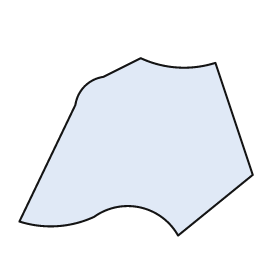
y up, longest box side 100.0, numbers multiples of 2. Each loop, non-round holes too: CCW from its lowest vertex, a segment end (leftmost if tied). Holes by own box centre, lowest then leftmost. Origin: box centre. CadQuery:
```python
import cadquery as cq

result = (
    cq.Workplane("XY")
    .moveTo(18.0, -38.0)
    .lineTo(50.0, -12.0)
    .lineTo(34.0, 36.0)
    .threePointArc((18.0, 34.0), (2.0, 38.0))
    .lineTo(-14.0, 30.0)
    .threePointArc((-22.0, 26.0), (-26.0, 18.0))
    .lineTo(-50.0, -32.0)
    .threePointArc((-34.0, -34.0), (-18.0, -30.0))
    .threePointArc((2.0, -26.0), (18.0, -38.0))
    .close()
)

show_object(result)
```